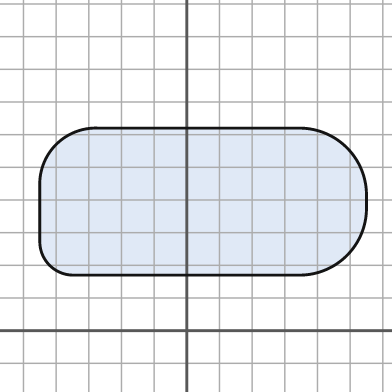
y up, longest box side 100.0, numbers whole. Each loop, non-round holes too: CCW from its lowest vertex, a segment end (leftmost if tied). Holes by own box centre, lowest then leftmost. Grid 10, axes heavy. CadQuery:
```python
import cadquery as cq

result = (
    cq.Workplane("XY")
    .moveTo(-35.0, 17.0)
    .lineTo(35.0, 17.0)
    .threePointArc((49.0, 23.0), (55.0, 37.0))
    .lineTo(55.0, 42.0)
    .threePointArc((49.0, 56.0), (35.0, 62.0))
    .lineTo(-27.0, 62.0)
    .threePointArc((-40.0, 57.0), (-45.0, 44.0))
    .lineTo(-45.0, 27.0)
    .threePointArc((-42.0, 20.0), (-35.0, 17.0))
    .close()
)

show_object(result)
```